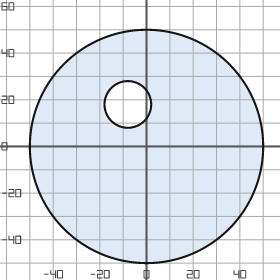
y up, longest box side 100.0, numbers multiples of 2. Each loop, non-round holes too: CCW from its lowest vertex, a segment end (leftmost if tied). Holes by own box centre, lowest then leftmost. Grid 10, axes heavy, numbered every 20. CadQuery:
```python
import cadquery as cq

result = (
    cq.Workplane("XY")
    .moveTo(0.0, 0.0)
    .circle(50.0)
    .moveTo(-8.0, 18.0)
    .circle(10.0)
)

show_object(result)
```